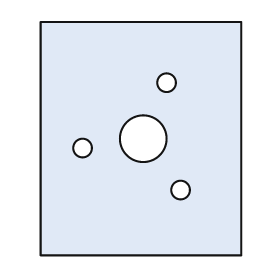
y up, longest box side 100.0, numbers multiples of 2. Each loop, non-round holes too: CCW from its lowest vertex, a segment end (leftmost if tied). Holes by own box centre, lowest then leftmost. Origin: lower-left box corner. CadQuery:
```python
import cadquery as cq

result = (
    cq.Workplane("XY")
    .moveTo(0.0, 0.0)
    .lineTo(86.0, 0.0)
    .lineTo(86.0, 100.0)
    .lineTo(0.0, 100.0)
    .close()
    .moveTo(60.0, 28.0)
    .circle(4.0)
    .moveTo(18.0, 46.0)
    .circle(4.0)
    .moveTo(44.0, 50.0)
    .circle(10.0)
    .moveTo(54.0, 74.0)
    .circle(4.0)
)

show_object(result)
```